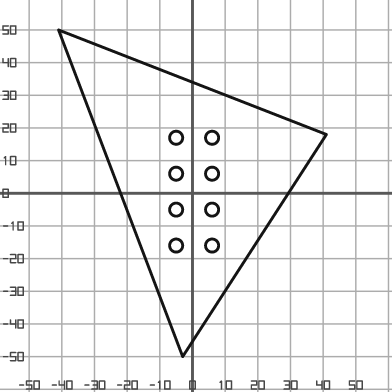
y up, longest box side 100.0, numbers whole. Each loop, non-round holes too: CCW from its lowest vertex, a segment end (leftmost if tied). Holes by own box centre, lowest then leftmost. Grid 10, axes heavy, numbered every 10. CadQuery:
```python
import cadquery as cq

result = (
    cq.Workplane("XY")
    .moveTo(-3.0, -50.0)
    .lineTo(41.0, 18.0)
    .lineTo(-41.0, 50.0)
    .close()
    .moveTo(-5.0, -16.0)
    .circle(2.0)
    .moveTo(6.0, -16.0)
    .circle(2.0)
    .moveTo(-5.0, -5.0)
    .circle(2.0)
    .moveTo(6.0, -5.0)
    .circle(2.0)
    .moveTo(-5.0, 6.0)
    .circle(2.0)
    .moveTo(6.0, 6.0)
    .circle(2.0)
    .moveTo(-5.0, 17.0)
    .circle(2.0)
    .moveTo(6.0, 17.0)
    .circle(2.0)
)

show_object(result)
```